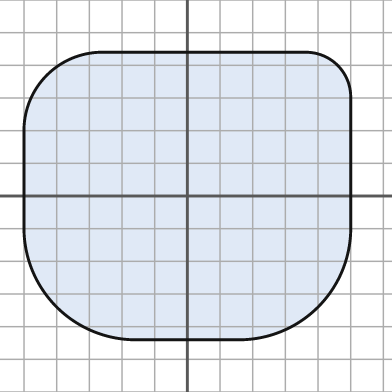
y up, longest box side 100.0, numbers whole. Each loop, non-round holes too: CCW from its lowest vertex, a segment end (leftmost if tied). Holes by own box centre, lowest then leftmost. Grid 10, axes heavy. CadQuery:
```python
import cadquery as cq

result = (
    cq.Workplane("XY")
    .moveTo(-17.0, -44.0)
    .lineTo(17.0, -44.0)
    .threePointArc((40.0, -34.0), (50.0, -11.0))
    .lineTo(50.0, 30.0)
    .threePointArc((46.0, 40.0), (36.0, 44.0))
    .lineTo(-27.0, 44.0)
    .threePointArc((-43.0, 37.0), (-50.0, 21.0))
    .lineTo(-50.0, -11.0)
    .threePointArc((-40.0, -34.0), (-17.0, -44.0))
    .close()
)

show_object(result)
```